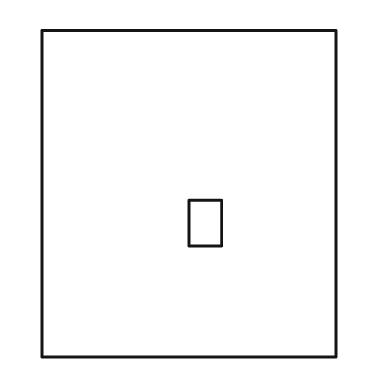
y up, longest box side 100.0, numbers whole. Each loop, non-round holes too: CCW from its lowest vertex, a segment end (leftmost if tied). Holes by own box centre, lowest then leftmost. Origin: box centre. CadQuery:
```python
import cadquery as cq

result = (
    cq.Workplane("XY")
    .moveTo(-45.0, -50.0)
    .lineTo(45.0, -50.0)
    .lineTo(45.0, 50.0)
    .lineTo(-45.0, 50.0)
    .close()
    .moveTo(0.0, -16.0)
    .lineTo(10.0, -16.0)
    .lineTo(10.0, -2.0)
    .lineTo(0.0, -2.0)
    .close()
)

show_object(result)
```